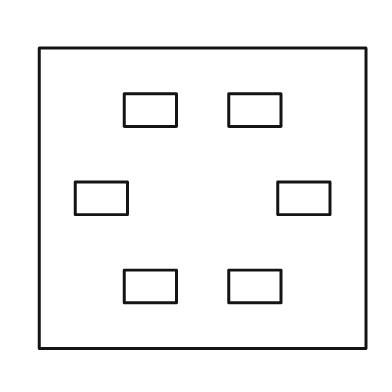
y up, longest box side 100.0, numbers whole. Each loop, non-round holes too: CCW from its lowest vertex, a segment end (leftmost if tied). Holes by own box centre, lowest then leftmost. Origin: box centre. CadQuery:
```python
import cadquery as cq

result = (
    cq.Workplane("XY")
    .moveTo(-50.0, -46.0)
    .lineTo(50.0, -46.0)
    .lineTo(50.0, 46.0)
    .lineTo(-50.0, 46.0)
    .close()
    .moveTo(-24.0, -32.0)
    .lineTo(-8.0, -32.0)
    .lineTo(-8.0, -22.0)
    .lineTo(-24.0, -22.0)
    .close()
    .moveTo(8.0, -32.0)
    .lineTo(24.0, -32.0)
    .lineTo(24.0, -22.0)
    .lineTo(8.0, -22.0)
    .close()
    .moveTo(-39.0, -5.0)
    .lineTo(-23.0, -5.0)
    .lineTo(-23.0, 5.0)
    .lineTo(-39.0, 5.0)
    .close()
    .moveTo(23.0, -5.0)
    .lineTo(39.0, -5.0)
    .lineTo(39.0, 5.0)
    .lineTo(23.0, 5.0)
    .close()
    .moveTo(-24.0, 22.0)
    .lineTo(-8.0, 22.0)
    .lineTo(-8.0, 32.0)
    .lineTo(-24.0, 32.0)
    .close()
    .moveTo(8.0, 22.0)
    .lineTo(24.0, 22.0)
    .lineTo(24.0, 32.0)
    .lineTo(8.0, 32.0)
    .close()
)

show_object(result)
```